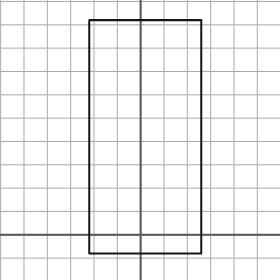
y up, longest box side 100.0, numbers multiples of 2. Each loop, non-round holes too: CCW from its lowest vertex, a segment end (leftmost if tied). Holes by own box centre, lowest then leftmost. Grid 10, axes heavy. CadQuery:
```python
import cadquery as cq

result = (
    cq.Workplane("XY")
    .moveTo(-22.0, -8.0)
    .lineTo(26.0, -8.0)
    .lineTo(26.0, 92.0)
    .lineTo(-22.0, 92.0)
    .close()
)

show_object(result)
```